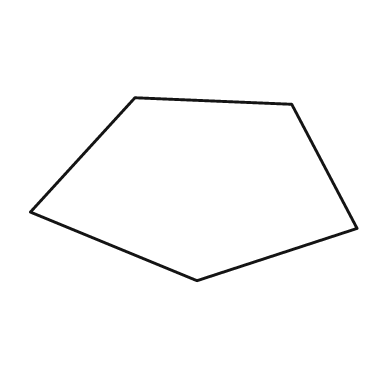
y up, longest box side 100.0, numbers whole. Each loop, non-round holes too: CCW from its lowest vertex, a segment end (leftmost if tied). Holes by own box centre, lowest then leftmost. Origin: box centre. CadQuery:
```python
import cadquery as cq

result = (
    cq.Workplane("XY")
    .moveTo(1.0, -28.0)
    .lineTo(50.0, -12.0)
    .lineTo(30.0, 26.0)
    .lineTo(-18.0, 28.0)
    .lineTo(-50.0, -7.0)
    .close()
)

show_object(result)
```